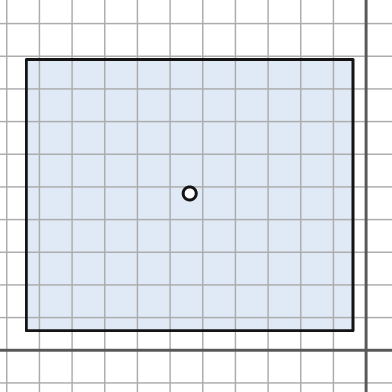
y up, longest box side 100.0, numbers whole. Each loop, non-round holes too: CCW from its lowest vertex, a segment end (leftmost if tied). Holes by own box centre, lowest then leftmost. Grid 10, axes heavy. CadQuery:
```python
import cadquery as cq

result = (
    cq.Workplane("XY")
    .moveTo(-104.0, 6.0)
    .lineTo(-4.0, 6.0)
    .lineTo(-4.0, 89.0)
    .lineTo(-104.0, 89.0)
    .close()
    .moveTo(-54.0, 48.0)
    .circle(2.0)
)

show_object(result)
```